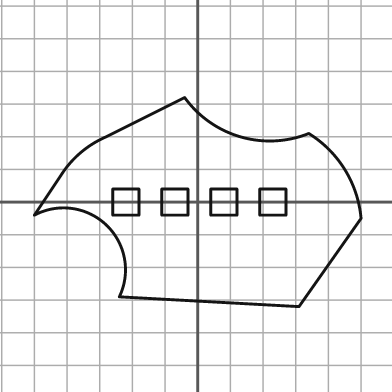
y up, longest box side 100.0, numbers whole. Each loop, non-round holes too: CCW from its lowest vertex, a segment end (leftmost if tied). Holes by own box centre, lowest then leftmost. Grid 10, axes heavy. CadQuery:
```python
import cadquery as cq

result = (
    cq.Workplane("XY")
    .moveTo(31.0, -32.0)
    .lineTo(50.0, -5.0)
    .threePointArc((45.0, 10.0), (34.0, 21.0))
    .threePointArc((13.0, 20.0), (-4.0, 32.0))
    .lineTo(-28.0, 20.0)
    .threePointArc((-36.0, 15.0), (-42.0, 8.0))
    .lineTo(-50.0, -4.0)
    .threePointArc((-28.0, -7.0), (-24.0, -29.0))
    .close()
    .moveTo(-26.0, -4.0)
    .lineTo(-18.0, -4.0)
    .lineTo(-18.0, 4.0)
    .lineTo(-26.0, 4.0)
    .close()
    .moveTo(-11.0, -4.0)
    .lineTo(-3.0, -4.0)
    .lineTo(-3.0, 4.0)
    .lineTo(-11.0, 4.0)
    .close()
    .moveTo(4.0, -4.0)
    .lineTo(12.0, -4.0)
    .lineTo(12.0, 4.0)
    .lineTo(4.0, 4.0)
    .close()
    .moveTo(19.0, -4.0)
    .lineTo(27.0, -4.0)
    .lineTo(27.0, 4.0)
    .lineTo(19.0, 4.0)
    .close()
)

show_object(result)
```